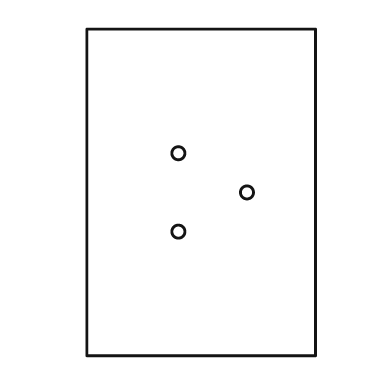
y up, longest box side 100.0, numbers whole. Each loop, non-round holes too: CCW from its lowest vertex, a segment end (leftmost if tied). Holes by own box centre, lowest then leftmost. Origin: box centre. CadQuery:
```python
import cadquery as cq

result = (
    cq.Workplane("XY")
    .moveTo(-35.0, -50.0)
    .lineTo(35.0, -50.0)
    .lineTo(35.0, 50.0)
    .lineTo(-35.0, 50.0)
    .close()
    .moveTo(-7.0, -12.0)
    .circle(2.0)
    .moveTo(14.0, 0.0)
    .circle(2.0)
    .moveTo(-7.0, 12.0)
    .circle(2.0)
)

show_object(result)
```